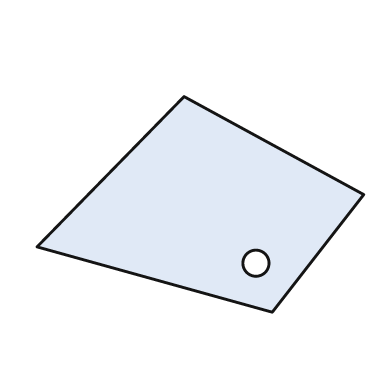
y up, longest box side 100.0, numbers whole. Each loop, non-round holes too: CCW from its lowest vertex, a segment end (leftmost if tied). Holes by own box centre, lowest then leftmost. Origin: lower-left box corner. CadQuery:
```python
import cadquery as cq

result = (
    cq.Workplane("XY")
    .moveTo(72.0, 0.0)
    .lineTo(100.0, 36.0)
    .lineTo(45.0, 66.0)
    .lineTo(0.0, 20.0)
    .close()
    .moveTo(67.0, 15.0)
    .circle(4.0)
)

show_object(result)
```